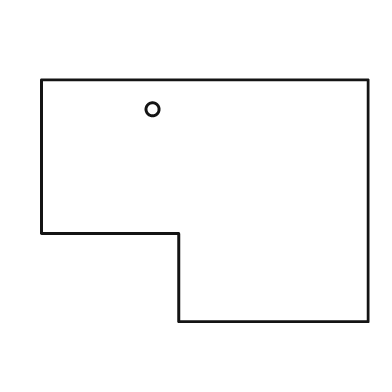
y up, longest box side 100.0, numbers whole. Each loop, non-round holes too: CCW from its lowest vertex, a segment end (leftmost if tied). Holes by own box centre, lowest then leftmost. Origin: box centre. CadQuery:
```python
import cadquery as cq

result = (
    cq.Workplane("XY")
    .moveTo(-8.0, -37.0)
    .lineTo(50.0, -37.0)
    .lineTo(50.0, 37.0)
    .lineTo(-50.0, 37.0)
    .lineTo(-50.0, -10.0)
    .lineTo(-8.0, -10.0)
    .close()
    .moveTo(-16.0, 28.0)
    .circle(2.0)
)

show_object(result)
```